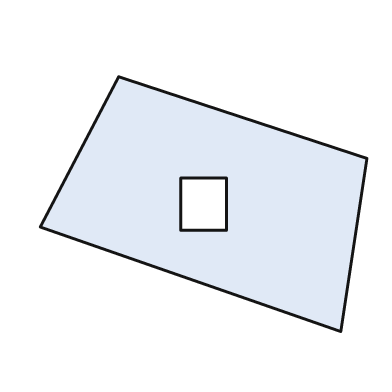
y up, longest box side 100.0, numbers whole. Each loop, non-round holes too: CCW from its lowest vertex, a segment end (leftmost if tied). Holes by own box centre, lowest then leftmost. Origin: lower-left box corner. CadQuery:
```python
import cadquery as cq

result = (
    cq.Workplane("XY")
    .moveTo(92.0, 0.0)
    .lineTo(100.0, 53.0)
    .lineTo(24.0, 78.0)
    .lineTo(0.0, 32.0)
    .close()
    .moveTo(43.0, 31.0)
    .lineTo(57.0, 31.0)
    .lineTo(57.0, 47.0)
    .lineTo(43.0, 47.0)
    .close()
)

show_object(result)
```